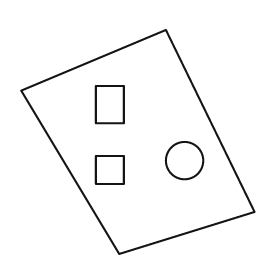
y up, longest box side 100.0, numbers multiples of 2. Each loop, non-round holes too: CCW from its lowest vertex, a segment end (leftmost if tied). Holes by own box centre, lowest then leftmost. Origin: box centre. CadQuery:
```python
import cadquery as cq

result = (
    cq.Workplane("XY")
    .moveTo(-8.0, -48.0)
    .lineTo(50.0, -30.0)
    .lineTo(12.0, 48.0)
    .lineTo(-50.0, 22.0)
    .close()
    .moveTo(-18.0, -18.0)
    .lineTo(-6.0, -18.0)
    .lineTo(-6.0, -6.0)
    .lineTo(-18.0, -6.0)
    .close()
    .moveTo(20.0, -8.0)
    .circle(8.0)
    .moveTo(-18.0, 8.0)
    .lineTo(-6.0, 8.0)
    .lineTo(-6.0, 24.0)
    .lineTo(-18.0, 24.0)
    .close()
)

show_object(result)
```